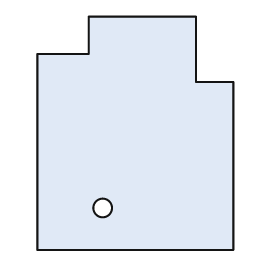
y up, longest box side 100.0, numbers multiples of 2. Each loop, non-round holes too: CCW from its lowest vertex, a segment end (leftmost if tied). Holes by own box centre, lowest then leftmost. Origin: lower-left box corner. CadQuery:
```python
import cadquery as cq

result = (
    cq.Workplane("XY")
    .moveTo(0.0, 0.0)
    .lineTo(84.0, 0.0)
    .lineTo(84.0, 72.0)
    .lineTo(68.0, 72.0)
    .lineTo(68.0, 100.0)
    .lineTo(22.0, 100.0)
    .lineTo(22.0, 84.0)
    .lineTo(0.0, 84.0)
    .close()
    .moveTo(28.0, 18.0)
    .circle(4.0)
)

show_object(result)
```